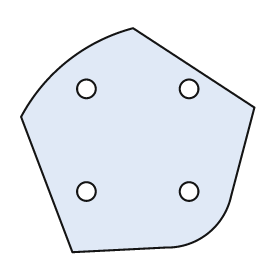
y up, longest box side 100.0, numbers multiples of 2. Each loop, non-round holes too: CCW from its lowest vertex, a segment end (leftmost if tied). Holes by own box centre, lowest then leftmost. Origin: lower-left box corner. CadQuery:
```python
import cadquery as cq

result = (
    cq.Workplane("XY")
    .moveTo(22.0, 0.0)
    .lineTo(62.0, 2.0)
    .threePointArc((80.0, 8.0), (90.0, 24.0))
    .lineTo(100.0, 62.0)
    .lineTo(48.0, 96.0)
    .threePointArc((20.0, 82.0), (0.0, 58.0))
    .close()
    .moveTo(28.0, 26.0)
    .circle(4.0)
    .moveTo(72.0, 26.0)
    .circle(4.0)
    .moveTo(28.0, 70.0)
    .circle(4.0)
    .moveTo(72.0, 70.0)
    .circle(4.0)
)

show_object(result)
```